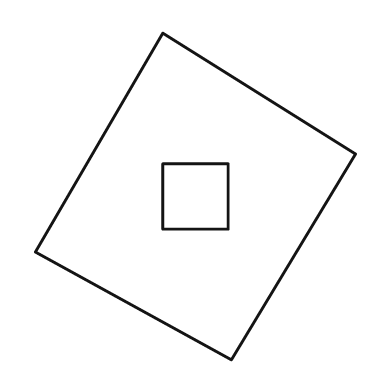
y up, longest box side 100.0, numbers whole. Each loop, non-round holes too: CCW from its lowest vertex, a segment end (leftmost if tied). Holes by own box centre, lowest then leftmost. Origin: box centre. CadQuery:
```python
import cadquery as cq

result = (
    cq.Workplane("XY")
    .moveTo(11.0, -50.0)
    .lineTo(49.0, 13.0)
    .lineTo(-10.0, 50.0)
    .lineTo(-49.0, -17.0)
    .close()
    .moveTo(-10.0, -10.0)
    .lineTo(10.0, -10.0)
    .lineTo(10.0, 10.0)
    .lineTo(-10.0, 10.0)
    .close()
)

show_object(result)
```